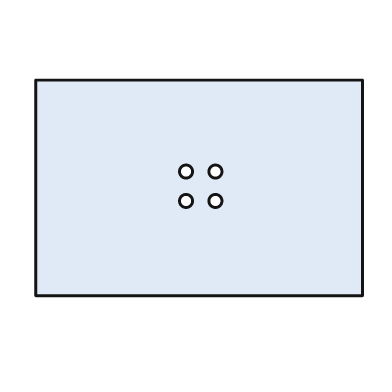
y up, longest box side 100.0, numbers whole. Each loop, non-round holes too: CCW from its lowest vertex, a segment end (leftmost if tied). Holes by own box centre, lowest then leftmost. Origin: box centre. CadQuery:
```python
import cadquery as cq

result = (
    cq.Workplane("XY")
    .moveTo(-50.0, -33.0)
    .lineTo(50.0, -33.0)
    .lineTo(50.0, 33.0)
    .lineTo(-50.0, 33.0)
    .close()
    .moveTo(-4.0, -4.0)
    .circle(2.0)
    .moveTo(5.0, -4.0)
    .circle(2.0)
    .moveTo(-4.0, 5.0)
    .circle(2.0)
    .moveTo(5.0, 5.0)
    .circle(2.0)
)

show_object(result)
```